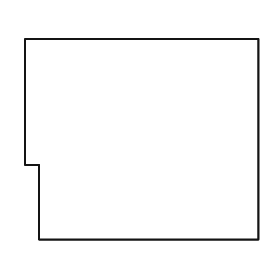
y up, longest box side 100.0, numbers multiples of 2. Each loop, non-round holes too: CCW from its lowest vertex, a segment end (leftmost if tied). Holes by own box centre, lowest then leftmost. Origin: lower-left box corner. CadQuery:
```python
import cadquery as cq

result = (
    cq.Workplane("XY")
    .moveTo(6.0, 0.0)
    .lineTo(100.0, 0.0)
    .lineTo(100.0, 86.0)
    .lineTo(0.0, 86.0)
    .lineTo(0.0, 32.0)
    .lineTo(6.0, 32.0)
    .close()
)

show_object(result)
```